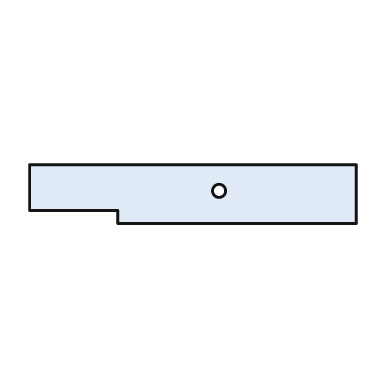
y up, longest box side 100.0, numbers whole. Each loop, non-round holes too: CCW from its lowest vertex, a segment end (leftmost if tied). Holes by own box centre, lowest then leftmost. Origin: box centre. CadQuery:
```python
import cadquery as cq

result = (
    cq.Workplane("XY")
    .moveTo(-23.0, -9.0)
    .lineTo(50.0, -9.0)
    .lineTo(50.0, 9.0)
    .lineTo(-50.0, 9.0)
    .lineTo(-50.0, -5.0)
    .lineTo(-23.0, -5.0)
    .close()
    .moveTo(8.0, 1.0)
    .circle(2.0)
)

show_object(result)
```